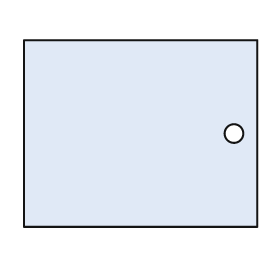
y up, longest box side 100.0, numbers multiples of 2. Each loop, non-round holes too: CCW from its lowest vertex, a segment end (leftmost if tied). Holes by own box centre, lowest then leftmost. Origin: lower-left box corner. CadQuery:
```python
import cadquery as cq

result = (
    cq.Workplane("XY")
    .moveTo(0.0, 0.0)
    .lineTo(100.0, 0.0)
    .lineTo(100.0, 80.0)
    .lineTo(0.0, 80.0)
    .close()
    .moveTo(90.0, 40.0)
    .circle(4.0)
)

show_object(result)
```